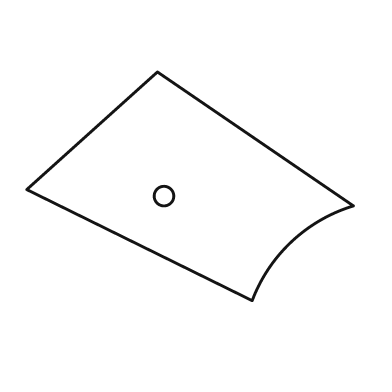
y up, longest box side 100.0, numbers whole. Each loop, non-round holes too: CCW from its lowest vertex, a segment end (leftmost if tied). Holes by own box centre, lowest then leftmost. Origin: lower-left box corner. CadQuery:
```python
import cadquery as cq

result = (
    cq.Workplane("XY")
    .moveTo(69.0, 0.0)
    .threePointArc((81.0, 18.0), (100.0, 29.0))
    .lineTo(40.0, 70.0)
    .lineTo(0.0, 34.0)
    .close()
    .moveTo(42.0, 32.0)
    .circle(3.0)
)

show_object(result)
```